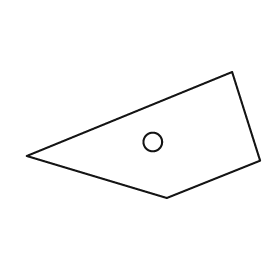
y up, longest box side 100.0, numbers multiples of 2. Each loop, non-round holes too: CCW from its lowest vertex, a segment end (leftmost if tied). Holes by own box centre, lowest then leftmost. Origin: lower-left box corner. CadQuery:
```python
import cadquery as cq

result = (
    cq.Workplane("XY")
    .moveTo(60.0, 0.0)
    .lineTo(100.0, 16.0)
    .lineTo(88.0, 54.0)
    .lineTo(0.0, 18.0)
    .close()
    .moveTo(54.0, 24.0)
    .circle(4.0)
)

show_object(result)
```